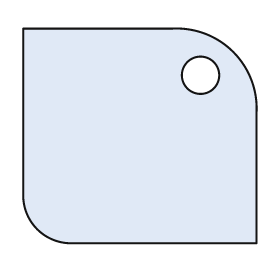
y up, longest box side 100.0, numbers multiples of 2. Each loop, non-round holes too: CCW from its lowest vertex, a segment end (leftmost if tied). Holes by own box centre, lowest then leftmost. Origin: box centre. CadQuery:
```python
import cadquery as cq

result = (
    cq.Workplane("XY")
    .moveTo(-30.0, -46.0)
    .lineTo(50.0, -46.0)
    .lineTo(50.0, 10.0)
    .threePointArc((40.0, 36.0), (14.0, 46.0))
    .lineTo(-50.0, 46.0)
    .lineTo(-50.0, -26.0)
    .threePointArc((-44.0, -40.0), (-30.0, -46.0))
    .close()
    .moveTo(26.0, 26.0)
    .circle(8.0)
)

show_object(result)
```